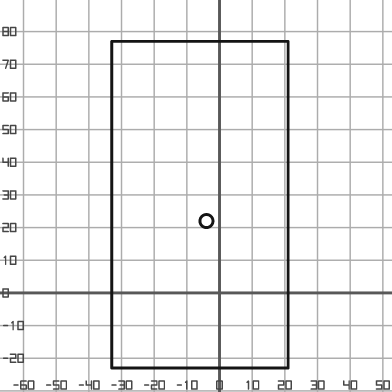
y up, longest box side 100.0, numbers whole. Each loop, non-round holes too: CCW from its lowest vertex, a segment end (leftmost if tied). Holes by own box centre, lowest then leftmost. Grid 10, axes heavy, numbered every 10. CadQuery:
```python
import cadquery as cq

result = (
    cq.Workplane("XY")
    .moveTo(-33.0, -23.0)
    .lineTo(21.0, -23.0)
    .lineTo(21.0, 77.0)
    .lineTo(-33.0, 77.0)
    .close()
    .moveTo(-4.0, 22.0)
    .circle(2.0)
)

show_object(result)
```